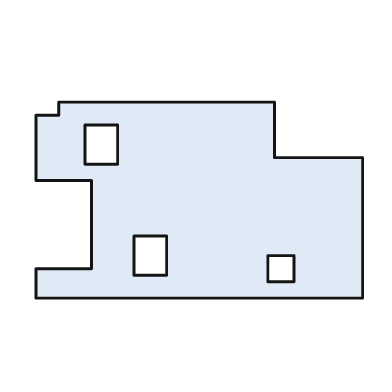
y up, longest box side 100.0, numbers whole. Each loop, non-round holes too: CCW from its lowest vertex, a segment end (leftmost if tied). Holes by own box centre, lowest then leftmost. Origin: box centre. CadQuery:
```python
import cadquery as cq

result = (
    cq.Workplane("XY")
    .moveTo(-50.0, -30.0)
    .lineTo(50.0, -30.0)
    .lineTo(50.0, 13.0)
    .lineTo(23.0, 13.0)
    .lineTo(23.0, 30.0)
    .lineTo(-43.0, 30.0)
    .lineTo(-43.0, 26.0)
    .lineTo(-50.0, 26.0)
    .lineTo(-50.0, 6.0)
    .lineTo(-33.0, 6.0)
    .lineTo(-33.0, -21.0)
    .lineTo(-50.0, -21.0)
    .close()
    .moveTo(21.0, -25.0)
    .lineTo(29.0, -25.0)
    .lineTo(29.0, -17.0)
    .lineTo(21.0, -17.0)
    .close()
    .moveTo(-20.0, -23.0)
    .lineTo(-10.0, -23.0)
    .lineTo(-10.0, -11.0)
    .lineTo(-20.0, -11.0)
    .close()
    .moveTo(-35.0, 11.0)
    .lineTo(-25.0, 11.0)
    .lineTo(-25.0, 23.0)
    .lineTo(-35.0, 23.0)
    .close()
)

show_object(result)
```